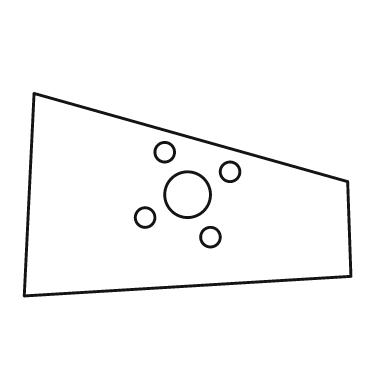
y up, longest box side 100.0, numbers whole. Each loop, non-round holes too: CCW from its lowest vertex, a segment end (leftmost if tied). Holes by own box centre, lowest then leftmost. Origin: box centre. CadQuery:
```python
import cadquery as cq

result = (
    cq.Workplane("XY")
    .moveTo(-50.0, -31.0)
    .lineTo(50.0, -25.0)
    .lineTo(49.0, 4.0)
    .lineTo(-47.0, 31.0)
    .close()
    .moveTo(7.0, -13.0)
    .circle(3.0)
    .moveTo(-13.0, -7.0)
    .circle(3.0)
    .moveTo(0.0, 0.0)
    .circle(7.0)
    .moveTo(13.0, 7.0)
    .circle(3.0)
    .moveTo(-7.0, 13.0)
    .circle(3.0)
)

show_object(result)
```